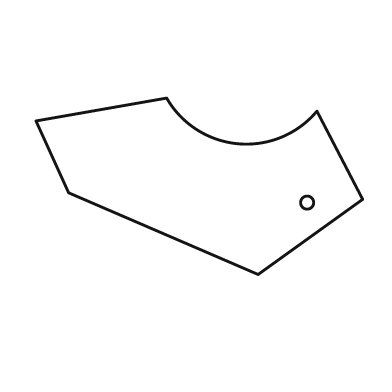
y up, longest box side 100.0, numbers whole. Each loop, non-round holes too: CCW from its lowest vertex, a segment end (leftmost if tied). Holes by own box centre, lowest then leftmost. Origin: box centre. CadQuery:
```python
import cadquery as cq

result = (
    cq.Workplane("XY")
    .moveTo(18.0, -27.0)
    .lineTo(50.0, -4.0)
    .lineTo(36.0, 23.0)
    .threePointArc((12.0, 13.0), (-10.0, 27.0))
    .lineTo(-50.0, 20.0)
    .lineTo(-40.0, -2.0)
    .close()
    .moveTo(33.0, -5.0)
    .circle(2.0)
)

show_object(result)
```